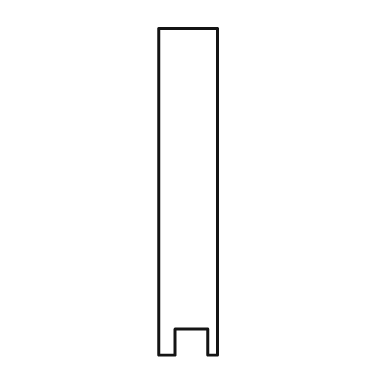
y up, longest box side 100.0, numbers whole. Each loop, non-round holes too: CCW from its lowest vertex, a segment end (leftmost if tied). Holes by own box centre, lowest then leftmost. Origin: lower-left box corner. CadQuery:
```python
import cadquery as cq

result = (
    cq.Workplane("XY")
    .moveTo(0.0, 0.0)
    .lineTo(5.0, 0.0)
    .lineTo(5.0, 8.0)
    .lineTo(15.0, 8.0)
    .lineTo(15.0, 0.0)
    .lineTo(18.0, 0.0)
    .lineTo(18.0, 100.0)
    .lineTo(0.0, 100.0)
    .close()
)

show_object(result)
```